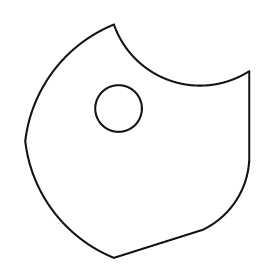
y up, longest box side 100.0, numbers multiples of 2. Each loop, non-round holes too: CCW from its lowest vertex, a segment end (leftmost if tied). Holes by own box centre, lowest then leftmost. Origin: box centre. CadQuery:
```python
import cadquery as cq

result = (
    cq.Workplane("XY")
    .moveTo(-10.0, -50.0)
    .lineTo(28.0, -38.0)
    .threePointArc((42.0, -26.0), (48.0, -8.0))
    .lineTo(48.0, 30.0)
    .threePointArc((14.0, 26.0), (-10.0, 50.0))
    .threePointArc((-36.0, 30.0), (-48.0, 0.0))
    .threePointArc((-36.0, -30.0), (-10.0, -50.0))
    .close()
    .moveTo(-8.0, 14.0)
    .circle(10.0)
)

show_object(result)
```